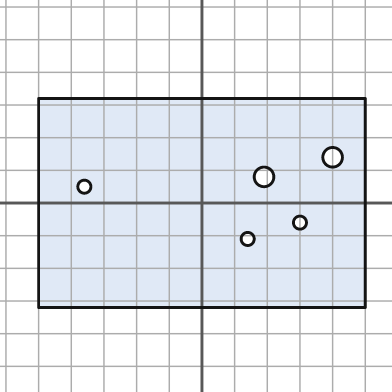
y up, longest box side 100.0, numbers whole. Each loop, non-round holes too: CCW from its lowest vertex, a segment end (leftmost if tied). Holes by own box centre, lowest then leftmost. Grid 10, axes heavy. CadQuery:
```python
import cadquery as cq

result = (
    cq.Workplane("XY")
    .moveTo(-50.0, -32.0)
    .lineTo(50.0, -32.0)
    .lineTo(50.0, 32.0)
    .lineTo(-50.0, 32.0)
    .close()
    .moveTo(14.0, -11.0)
    .circle(2.0)
    .moveTo(30.0, -6.0)
    .circle(2.0)
    .moveTo(-36.0, 5.0)
    .circle(2.0)
    .moveTo(19.0, 8.0)
    .circle(3.0)
    .moveTo(40.0, 14.0)
    .circle(3.0)
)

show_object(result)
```